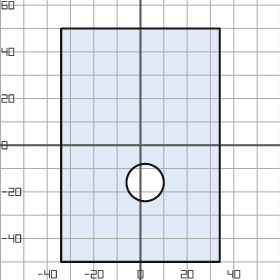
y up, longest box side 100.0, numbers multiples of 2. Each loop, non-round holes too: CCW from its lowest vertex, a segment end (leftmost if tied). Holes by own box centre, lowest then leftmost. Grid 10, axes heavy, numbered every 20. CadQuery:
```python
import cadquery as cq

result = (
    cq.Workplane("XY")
    .moveTo(-34.0, -50.0)
    .lineTo(34.0, -50.0)
    .lineTo(34.0, 50.0)
    .lineTo(-34.0, 50.0)
    .close()
    .moveTo(2.0, -16.0)
    .circle(8.0)
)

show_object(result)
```